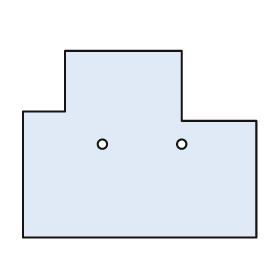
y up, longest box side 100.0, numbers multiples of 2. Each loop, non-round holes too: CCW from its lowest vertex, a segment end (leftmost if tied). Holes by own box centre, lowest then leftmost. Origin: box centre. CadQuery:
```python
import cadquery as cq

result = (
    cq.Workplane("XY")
    .moveTo(-50.0, -40.0)
    .lineTo(50.0, -40.0)
    .lineTo(50.0, 10.0)
    .lineTo(18.0, 10.0)
    .lineTo(18.0, 40.0)
    .lineTo(-32.0, 40.0)
    .lineTo(-32.0, 14.0)
    .lineTo(-50.0, 14.0)
    .close()
    .moveTo(-16.0, 0.0)
    .circle(2.0)
    .moveTo(18.0, 0.0)
    .circle(2.0)
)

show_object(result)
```